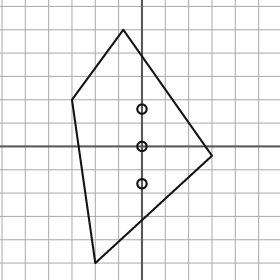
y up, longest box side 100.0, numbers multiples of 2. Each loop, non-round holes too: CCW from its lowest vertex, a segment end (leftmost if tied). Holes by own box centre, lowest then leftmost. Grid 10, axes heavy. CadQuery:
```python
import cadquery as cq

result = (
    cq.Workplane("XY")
    .moveTo(-20.0, -50.0)
    .lineTo(30.0, -4.0)
    .lineTo(-8.0, 50.0)
    .lineTo(-30.0, 20.0)
    .close()
    .moveTo(0.0, -16.0)
    .circle(2.0)
    .moveTo(0.0, 0.0)
    .circle(2.0)
    .moveTo(0.0, 16.0)
    .circle(2.0)
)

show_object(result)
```